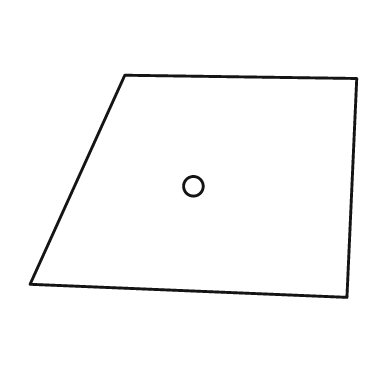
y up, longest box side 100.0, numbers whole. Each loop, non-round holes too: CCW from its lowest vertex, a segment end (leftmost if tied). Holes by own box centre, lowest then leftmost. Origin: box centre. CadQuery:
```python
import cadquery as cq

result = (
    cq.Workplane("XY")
    .moveTo(47.0, -34.0)
    .lineTo(50.0, 33.0)
    .lineTo(-21.0, 34.0)
    .lineTo(-50.0, -30.0)
    .close()
    .moveTo(0.0, 0.0)
    .circle(3.0)
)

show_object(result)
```